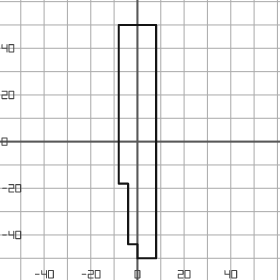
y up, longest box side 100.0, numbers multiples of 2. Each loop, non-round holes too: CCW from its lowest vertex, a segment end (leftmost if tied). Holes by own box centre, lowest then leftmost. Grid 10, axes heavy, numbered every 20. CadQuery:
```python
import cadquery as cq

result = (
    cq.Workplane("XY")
    .moveTo(0.0, -50.0)
    .lineTo(8.0, -50.0)
    .lineTo(8.0, 50.0)
    .lineTo(-8.0, 50.0)
    .lineTo(-8.0, -18.0)
    .lineTo(-4.0, -18.0)
    .lineTo(-4.0, -44.0)
    .lineTo(0.0, -44.0)
    .close()
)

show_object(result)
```